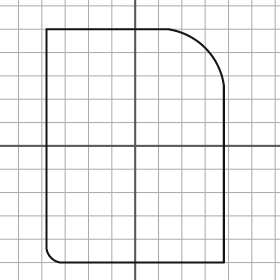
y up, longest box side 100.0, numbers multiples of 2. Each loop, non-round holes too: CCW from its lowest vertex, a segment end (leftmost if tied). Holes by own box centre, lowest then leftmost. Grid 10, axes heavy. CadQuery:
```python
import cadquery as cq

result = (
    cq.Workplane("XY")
    .moveTo(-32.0, -50.0)
    .lineTo(38.0, -50.0)
    .lineTo(38.0, 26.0)
    .threePointArc((30.0, 42.0), (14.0, 50.0))
    .lineTo(-38.0, 50.0)
    .lineTo(-38.0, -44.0)
    .threePointArc((-36.0, -48.0), (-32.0, -50.0))
    .close()
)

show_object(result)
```